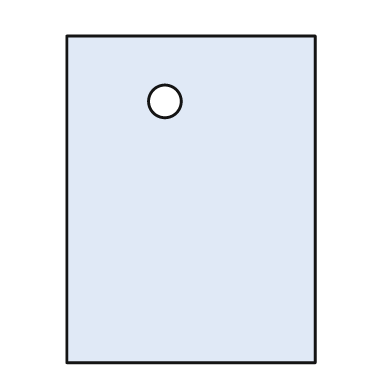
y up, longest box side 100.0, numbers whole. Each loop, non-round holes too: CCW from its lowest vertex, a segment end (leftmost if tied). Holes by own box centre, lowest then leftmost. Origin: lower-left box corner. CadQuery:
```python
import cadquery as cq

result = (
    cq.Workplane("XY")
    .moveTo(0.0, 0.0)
    .lineTo(76.0, 0.0)
    .lineTo(76.0, 100.0)
    .lineTo(0.0, 100.0)
    .close()
    .moveTo(30.0, 80.0)
    .circle(5.0)
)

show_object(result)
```